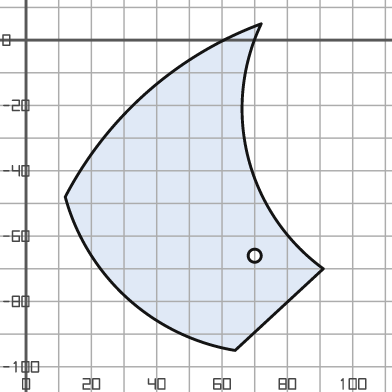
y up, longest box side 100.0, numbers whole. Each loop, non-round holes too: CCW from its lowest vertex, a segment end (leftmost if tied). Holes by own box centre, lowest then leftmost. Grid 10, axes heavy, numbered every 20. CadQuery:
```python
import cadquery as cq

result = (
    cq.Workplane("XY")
    .moveTo(64.0, -95.0)
    .lineTo(91.0, -70.0)
    .threePointArc((68.0, -36.0), (72.0, 5.0))
    .threePointArc((37.0, -16.0), (12.0, -48.0))
    .threePointArc((31.0, -79.0), (64.0, -95.0))
    .close()
    .moveTo(70.0, -66.0)
    .circle(2.0)
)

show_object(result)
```